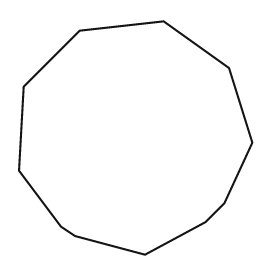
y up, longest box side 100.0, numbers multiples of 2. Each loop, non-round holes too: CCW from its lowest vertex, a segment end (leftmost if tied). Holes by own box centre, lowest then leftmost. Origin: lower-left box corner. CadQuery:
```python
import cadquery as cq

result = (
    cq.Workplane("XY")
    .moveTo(54.0, 0.0)
    .lineTo(80.0, 14.0)
    .lineTo(88.0, 22.0)
    .lineTo(100.0, 48.0)
    .lineTo(90.0, 80.0)
    .lineTo(62.0, 100.0)
    .lineTo(26.0, 96.0)
    .lineTo(2.0, 72.0)
    .lineTo(0.0, 36.0)
    .lineTo(18.0, 12.0)
    .lineTo(24.0, 8.0)
    .close()
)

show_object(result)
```